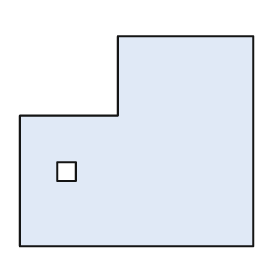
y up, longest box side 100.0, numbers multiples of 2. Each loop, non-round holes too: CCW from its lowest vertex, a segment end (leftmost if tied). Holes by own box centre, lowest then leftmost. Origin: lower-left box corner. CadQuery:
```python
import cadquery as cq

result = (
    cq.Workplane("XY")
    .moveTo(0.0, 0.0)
    .lineTo(100.0, 0.0)
    .lineTo(100.0, 90.0)
    .lineTo(42.0, 90.0)
    .lineTo(42.0, 56.0)
    .lineTo(0.0, 56.0)
    .close()
    .moveTo(16.0, 28.0)
    .lineTo(24.0, 28.0)
    .lineTo(24.0, 36.0)
    .lineTo(16.0, 36.0)
    .close()
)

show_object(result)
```